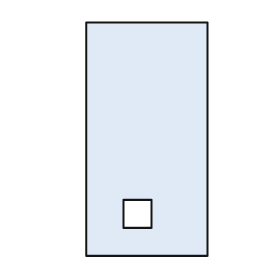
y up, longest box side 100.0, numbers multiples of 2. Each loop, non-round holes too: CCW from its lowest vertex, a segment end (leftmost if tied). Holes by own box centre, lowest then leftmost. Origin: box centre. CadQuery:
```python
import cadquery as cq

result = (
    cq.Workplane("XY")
    .moveTo(-26.0, -50.0)
    .lineTo(26.0, -50.0)
    .lineTo(26.0, 50.0)
    .lineTo(-26.0, 50.0)
    .close()
    .moveTo(-10.0, -38.0)
    .lineTo(2.0, -38.0)
    .lineTo(2.0, -26.0)
    .lineTo(-10.0, -26.0)
    .close()
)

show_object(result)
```